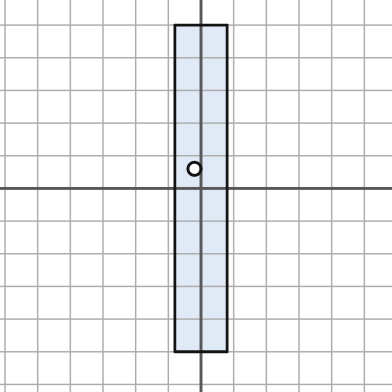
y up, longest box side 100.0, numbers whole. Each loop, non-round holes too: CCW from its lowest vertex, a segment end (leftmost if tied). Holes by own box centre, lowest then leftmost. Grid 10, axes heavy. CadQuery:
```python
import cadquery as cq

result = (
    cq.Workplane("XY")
    .moveTo(-8.0, -50.0)
    .lineTo(8.0, -50.0)
    .lineTo(8.0, 50.0)
    .lineTo(-8.0, 50.0)
    .close()
    .moveTo(-2.0, 6.0)
    .circle(2.0)
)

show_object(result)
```